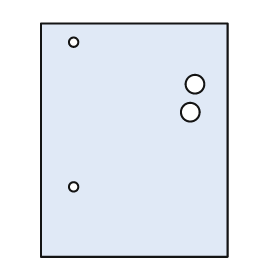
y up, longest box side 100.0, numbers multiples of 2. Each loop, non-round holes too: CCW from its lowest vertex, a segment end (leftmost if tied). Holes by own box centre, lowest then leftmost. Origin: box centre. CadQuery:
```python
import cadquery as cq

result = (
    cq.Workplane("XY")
    .moveTo(-40.0, -50.0)
    .lineTo(40.0, -50.0)
    .lineTo(40.0, 50.0)
    .lineTo(-40.0, 50.0)
    .close()
    .moveTo(-26.0, -20.0)
    .circle(2.0)
    .moveTo(24.0, 12.0)
    .circle(4.0)
    .moveTo(26.0, 24.0)
    .circle(4.0)
    .moveTo(-26.0, 42.0)
    .circle(2.0)
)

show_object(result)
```